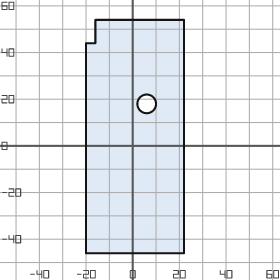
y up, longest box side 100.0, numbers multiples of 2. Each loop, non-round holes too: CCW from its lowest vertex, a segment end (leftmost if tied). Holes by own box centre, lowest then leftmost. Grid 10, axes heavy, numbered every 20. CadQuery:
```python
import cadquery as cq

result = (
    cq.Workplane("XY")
    .moveTo(-20.0, -46.0)
    .lineTo(22.0, -46.0)
    .lineTo(22.0, 54.0)
    .lineTo(-16.0, 54.0)
    .lineTo(-16.0, 44.0)
    .lineTo(-20.0, 44.0)
    .close()
    .moveTo(6.0, 18.0)
    .circle(4.0)
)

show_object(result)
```